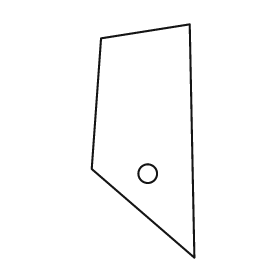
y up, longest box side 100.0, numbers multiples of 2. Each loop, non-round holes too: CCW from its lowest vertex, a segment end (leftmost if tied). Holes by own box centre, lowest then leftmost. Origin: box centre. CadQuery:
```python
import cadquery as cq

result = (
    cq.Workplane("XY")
    .moveTo(22.0, -50.0)
    .lineTo(20.0, 50.0)
    .lineTo(-18.0, 44.0)
    .lineTo(-22.0, -12.0)
    .close()
    .moveTo(2.0, -14.0)
    .circle(4.0)
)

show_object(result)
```